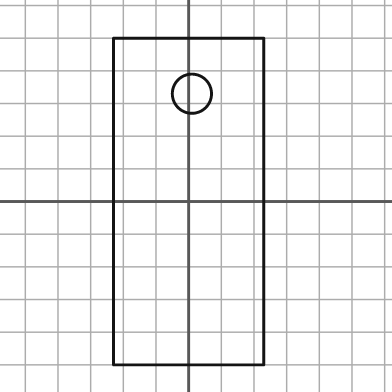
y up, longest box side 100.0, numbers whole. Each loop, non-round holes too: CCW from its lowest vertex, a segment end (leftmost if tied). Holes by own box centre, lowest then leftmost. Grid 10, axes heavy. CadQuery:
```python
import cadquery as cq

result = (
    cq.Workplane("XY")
    .moveTo(-23.0, -50.0)
    .lineTo(23.0, -50.0)
    .lineTo(23.0, 50.0)
    .lineTo(-23.0, 50.0)
    .close()
    .moveTo(1.0, 33.0)
    .circle(6.0)
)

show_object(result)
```